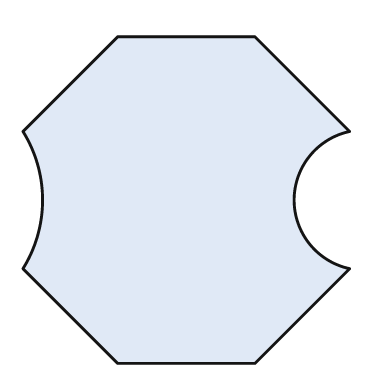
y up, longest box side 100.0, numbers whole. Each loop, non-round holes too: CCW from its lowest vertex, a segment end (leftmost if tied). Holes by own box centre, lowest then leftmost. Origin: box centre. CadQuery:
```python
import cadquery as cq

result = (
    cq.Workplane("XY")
    .moveTo(-21.0, -50.0)
    .lineTo(21.0, -50.0)
    .lineTo(50.0, -21.0)
    .threePointArc((33.0, 0.0), (50.0, 21.0))
    .lineTo(21.0, 50.0)
    .lineTo(-21.0, 50.0)
    .lineTo(-50.0, 21.0)
    .threePointArc((-44.0, 0.0), (-50.0, -21.0))
    .close()
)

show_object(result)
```